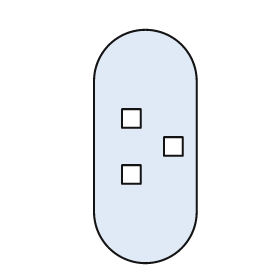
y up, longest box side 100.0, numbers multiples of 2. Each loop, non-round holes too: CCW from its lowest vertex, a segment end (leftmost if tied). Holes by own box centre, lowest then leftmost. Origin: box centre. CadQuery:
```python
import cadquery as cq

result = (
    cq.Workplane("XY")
    .moveTo(-22.0, -28.0)
    .threePointArc((0.0, -50.0), (22.0, -28.0))
    .lineTo(22.0, 28.0)
    .threePointArc((0.0, 50.0), (-22.0, 28.0))
    .close()
    .moveTo(-10.0, -16.0)
    .lineTo(-2.0, -16.0)
    .lineTo(-2.0, -8.0)
    .lineTo(-10.0, -8.0)
    .close()
    .moveTo(8.0, -4.0)
    .lineTo(16.0, -4.0)
    .lineTo(16.0, 4.0)
    .lineTo(8.0, 4.0)
    .close()
    .moveTo(-10.0, 8.0)
    .lineTo(-2.0, 8.0)
    .lineTo(-2.0, 16.0)
    .lineTo(-10.0, 16.0)
    .close()
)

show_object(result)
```